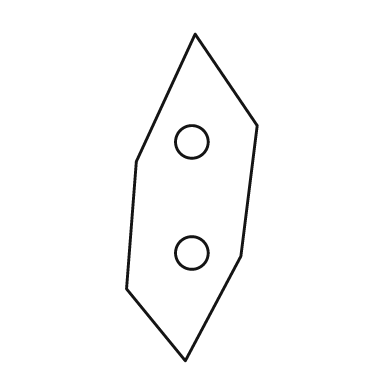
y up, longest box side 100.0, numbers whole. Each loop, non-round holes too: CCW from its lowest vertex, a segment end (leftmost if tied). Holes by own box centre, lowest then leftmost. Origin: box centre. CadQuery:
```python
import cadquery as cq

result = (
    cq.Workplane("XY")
    .moveTo(-2.0, -50.0)
    .lineTo(15.0, -18.0)
    .lineTo(20.0, 22.0)
    .lineTo(1.0, 50.0)
    .lineTo(-17.0, 11.0)
    .lineTo(-20.0, -28.0)
    .close()
    .moveTo(0.0, -17.0)
    .circle(5.0)
    .moveTo(0.0, 17.0)
    .circle(5.0)
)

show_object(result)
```